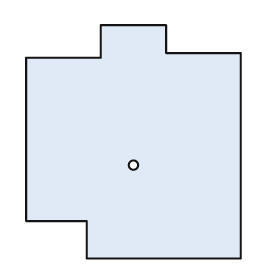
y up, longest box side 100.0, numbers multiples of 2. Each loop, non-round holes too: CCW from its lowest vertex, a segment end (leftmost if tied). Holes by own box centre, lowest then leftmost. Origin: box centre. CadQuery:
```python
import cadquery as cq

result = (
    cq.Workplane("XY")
    .moveTo(-20.0, -50.0)
    .lineTo(46.0, -50.0)
    .lineTo(46.0, 38.0)
    .lineTo(14.0, 38.0)
    .lineTo(14.0, 50.0)
    .lineTo(-14.0, 50.0)
    .lineTo(-14.0, 36.0)
    .lineTo(-46.0, 36.0)
    .lineTo(-46.0, -34.0)
    .lineTo(-20.0, -34.0)
    .close()
    .moveTo(0.0, -10.0)
    .circle(2.0)
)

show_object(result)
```